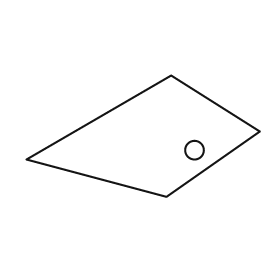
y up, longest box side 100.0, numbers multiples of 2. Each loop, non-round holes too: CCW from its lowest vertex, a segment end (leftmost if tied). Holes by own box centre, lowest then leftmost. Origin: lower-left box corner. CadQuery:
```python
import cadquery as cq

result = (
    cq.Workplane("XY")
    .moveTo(60.0, 0.0)
    .lineTo(100.0, 28.0)
    .lineTo(62.0, 52.0)
    .lineTo(0.0, 16.0)
    .close()
    .moveTo(72.0, 20.0)
    .circle(4.0)
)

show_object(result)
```